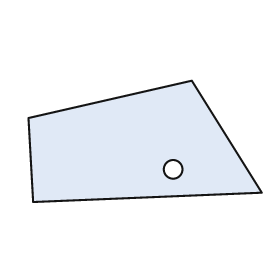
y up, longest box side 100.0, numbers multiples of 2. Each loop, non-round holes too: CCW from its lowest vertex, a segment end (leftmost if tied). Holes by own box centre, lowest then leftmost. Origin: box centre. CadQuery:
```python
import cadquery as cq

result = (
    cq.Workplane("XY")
    .moveTo(-48.0, -26.0)
    .lineTo(50.0, -22.0)
    .lineTo(20.0, 26.0)
    .lineTo(-50.0, 10.0)
    .close()
    .moveTo(12.0, -12.0)
    .circle(4.0)
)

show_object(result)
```